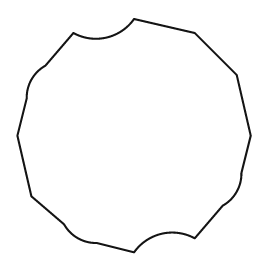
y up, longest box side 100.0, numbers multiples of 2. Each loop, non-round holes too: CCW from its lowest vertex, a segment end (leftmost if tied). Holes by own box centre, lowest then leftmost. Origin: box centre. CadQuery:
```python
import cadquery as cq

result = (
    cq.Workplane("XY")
    .moveTo(0.0, -50.0)
    .threePointArc((12.0, -42.0), (26.0, -44.0))
    .lineTo(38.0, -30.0)
    .threePointArc((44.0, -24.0), (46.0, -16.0))
    .lineTo(50.0, 0.0)
    .lineTo(44.0, 26.0)
    .lineTo(26.0, 44.0)
    .lineTo(0.0, 50.0)
    .threePointArc((-12.0, 42.0), (-26.0, 44.0))
    .lineTo(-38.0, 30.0)
    .threePointArc((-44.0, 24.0), (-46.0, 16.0))
    .lineTo(-50.0, 0.0)
    .lineTo(-44.0, -26.0)
    .lineTo(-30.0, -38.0)
    .threePointArc((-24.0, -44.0), (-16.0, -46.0))
    .close()
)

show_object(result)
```